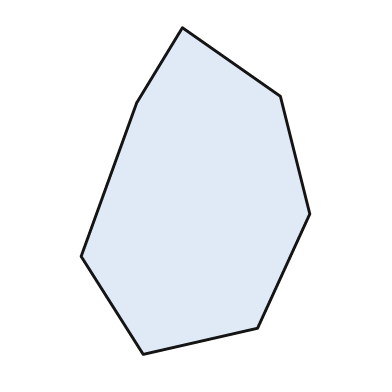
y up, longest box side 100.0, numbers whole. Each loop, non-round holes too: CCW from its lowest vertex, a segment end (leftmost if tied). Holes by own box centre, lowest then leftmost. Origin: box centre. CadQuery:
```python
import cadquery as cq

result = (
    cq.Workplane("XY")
    .moveTo(-16.0, -50.0)
    .lineTo(19.0, -42.0)
    .lineTo(35.0, -7.0)
    .lineTo(26.0, 29.0)
    .lineTo(-4.0, 50.0)
    .lineTo(-18.0, 27.0)
    .lineTo(-35.0, -20.0)
    .close()
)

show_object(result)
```